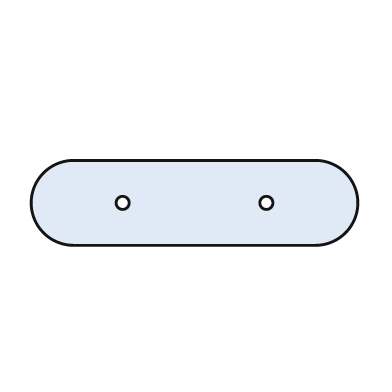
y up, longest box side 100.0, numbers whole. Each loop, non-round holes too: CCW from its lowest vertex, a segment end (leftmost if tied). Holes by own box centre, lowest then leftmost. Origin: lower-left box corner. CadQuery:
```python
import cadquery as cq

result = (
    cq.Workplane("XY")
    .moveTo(13.0, 0.0)
    .lineTo(87.0, 0.0)
    .threePointArc((100.0, 13.0), (87.0, 26.0))
    .lineTo(13.0, 26.0)
    .threePointArc((0.0, 13.0), (13.0, 0.0))
    .close()
    .moveTo(28.0, 13.0)
    .circle(2.0)
    .moveTo(72.0, 13.0)
    .circle(2.0)
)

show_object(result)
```